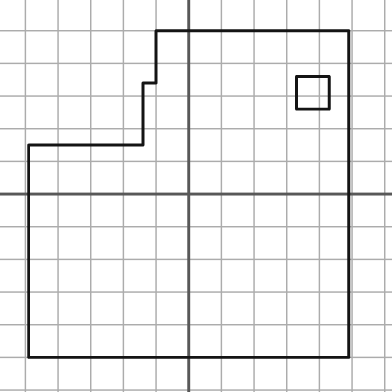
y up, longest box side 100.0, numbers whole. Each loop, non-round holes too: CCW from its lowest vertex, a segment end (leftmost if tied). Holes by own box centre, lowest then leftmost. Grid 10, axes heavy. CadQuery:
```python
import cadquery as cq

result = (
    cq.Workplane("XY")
    .moveTo(-49.0, -50.0)
    .lineTo(49.0, -50.0)
    .lineTo(49.0, 50.0)
    .lineTo(-10.0, 50.0)
    .lineTo(-10.0, 34.0)
    .lineTo(-14.0, 34.0)
    .lineTo(-14.0, 15.0)
    .lineTo(-49.0, 15.0)
    .close()
    .moveTo(33.0, 26.0)
    .lineTo(43.0, 26.0)
    .lineTo(43.0, 36.0)
    .lineTo(33.0, 36.0)
    .close()
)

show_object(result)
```